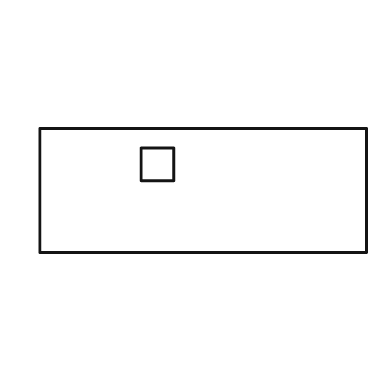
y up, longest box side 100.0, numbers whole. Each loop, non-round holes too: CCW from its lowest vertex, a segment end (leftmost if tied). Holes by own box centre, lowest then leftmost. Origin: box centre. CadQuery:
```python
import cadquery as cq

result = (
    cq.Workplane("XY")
    .moveTo(-50.0, -19.0)
    .lineTo(50.0, -19.0)
    .lineTo(50.0, 19.0)
    .lineTo(-50.0, 19.0)
    .close()
    .moveTo(-19.0, 3.0)
    .lineTo(-9.0, 3.0)
    .lineTo(-9.0, 13.0)
    .lineTo(-19.0, 13.0)
    .close()
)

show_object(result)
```